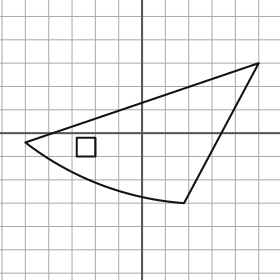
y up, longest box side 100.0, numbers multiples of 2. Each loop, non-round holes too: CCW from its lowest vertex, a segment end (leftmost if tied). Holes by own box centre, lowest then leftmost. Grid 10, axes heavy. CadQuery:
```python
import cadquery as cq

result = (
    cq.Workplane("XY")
    .moveTo(18.0, -30.0)
    .lineTo(50.0, 30.0)
    .lineTo(-50.0, -4.0)
    .threePointArc((-18.0, -22.0), (18.0, -30.0))
    .close()
    .moveTo(-28.0, -10.0)
    .lineTo(-20.0, -10.0)
    .lineTo(-20.0, -2.0)
    .lineTo(-28.0, -2.0)
    .close()
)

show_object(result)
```